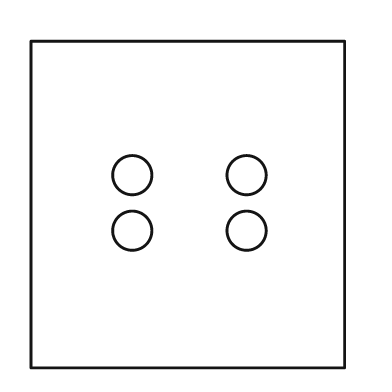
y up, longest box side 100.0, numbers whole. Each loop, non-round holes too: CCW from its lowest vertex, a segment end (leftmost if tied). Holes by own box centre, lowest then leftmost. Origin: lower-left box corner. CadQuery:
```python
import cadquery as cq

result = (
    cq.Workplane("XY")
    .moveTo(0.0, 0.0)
    .lineTo(96.0, 0.0)
    .lineTo(96.0, 100.0)
    .lineTo(0.0, 100.0)
    .close()
    .moveTo(31.0, 42.0)
    .circle(6.0)
    .moveTo(66.0, 42.0)
    .circle(6.0)
    .moveTo(31.0, 59.0)
    .circle(6.0)
    .moveTo(66.0, 59.0)
    .circle(6.0)
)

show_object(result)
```